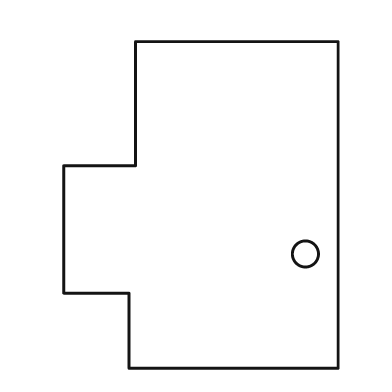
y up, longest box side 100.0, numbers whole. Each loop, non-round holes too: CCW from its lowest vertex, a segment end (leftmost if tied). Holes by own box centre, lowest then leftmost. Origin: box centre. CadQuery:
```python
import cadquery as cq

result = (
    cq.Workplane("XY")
    .moveTo(-22.0, -50.0)
    .lineTo(42.0, -50.0)
    .lineTo(42.0, 50.0)
    .lineTo(-20.0, 50.0)
    .lineTo(-20.0, 12.0)
    .lineTo(-42.0, 12.0)
    .lineTo(-42.0, -27.0)
    .lineTo(-22.0, -27.0)
    .close()
    .moveTo(32.0, -15.0)
    .circle(4.0)
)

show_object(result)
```